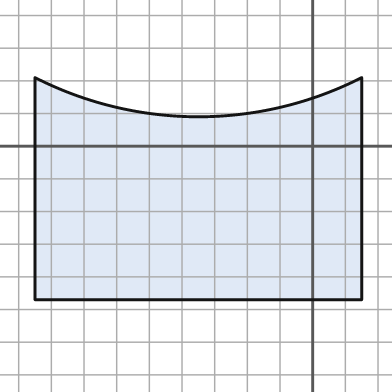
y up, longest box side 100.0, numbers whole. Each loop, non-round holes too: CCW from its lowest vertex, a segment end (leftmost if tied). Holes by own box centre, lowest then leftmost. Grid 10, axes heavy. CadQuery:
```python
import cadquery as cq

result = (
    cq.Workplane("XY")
    .moveTo(-85.0, -47.0)
    .lineTo(15.0, -47.0)
    .lineTo(15.0, 21.0)
    .threePointArc((-35.0, 9.0), (-85.0, 21.0))
    .close()
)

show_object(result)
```